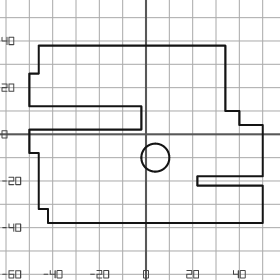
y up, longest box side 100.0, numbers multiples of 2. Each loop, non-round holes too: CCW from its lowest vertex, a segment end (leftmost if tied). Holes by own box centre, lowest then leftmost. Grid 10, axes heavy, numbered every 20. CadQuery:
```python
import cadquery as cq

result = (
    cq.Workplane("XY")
    .moveTo(-42.0, -38.0)
    .lineTo(50.0, -38.0)
    .lineTo(50.0, -22.0)
    .lineTo(22.0, -22.0)
    .lineTo(22.0, -18.0)
    .lineTo(50.0, -18.0)
    .lineTo(50.0, 4.0)
    .lineTo(40.0, 4.0)
    .lineTo(40.0, 10.0)
    .lineTo(34.0, 10.0)
    .lineTo(34.0, 38.0)
    .lineTo(-46.0, 38.0)
    .lineTo(-46.0, 26.0)
    .lineTo(-50.0, 26.0)
    .lineTo(-50.0, 12.0)
    .lineTo(-2.0, 12.0)
    .lineTo(-2.0, 2.0)
    .lineTo(-50.0, 2.0)
    .lineTo(-50.0, -8.0)
    .lineTo(-46.0, -8.0)
    .lineTo(-46.0, -32.0)
    .lineTo(-42.0, -32.0)
    .close()
    .moveTo(4.0, -10.0)
    .circle(6.0)
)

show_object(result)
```